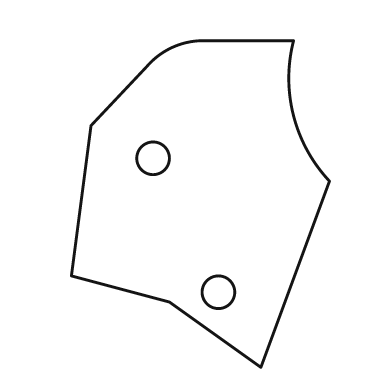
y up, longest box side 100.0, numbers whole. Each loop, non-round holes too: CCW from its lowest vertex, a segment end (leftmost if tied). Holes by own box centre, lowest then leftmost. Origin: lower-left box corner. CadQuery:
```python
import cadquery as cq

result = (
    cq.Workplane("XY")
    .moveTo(58.0, 0.0)
    .lineTo(79.0, 57.0)
    .threePointArc((68.0, 77.0), (68.0, 100.0))
    .lineTo(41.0, 100.0)
    .threePointArc((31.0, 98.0), (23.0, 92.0))
    .lineTo(6.0, 74.0)
    .lineTo(0.0, 28.0)
    .lineTo(30.0, 20.0)
    .close()
    .moveTo(45.0, 23.0)
    .circle(5.0)
    .moveTo(25.0, 64.0)
    .circle(5.0)
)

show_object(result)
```